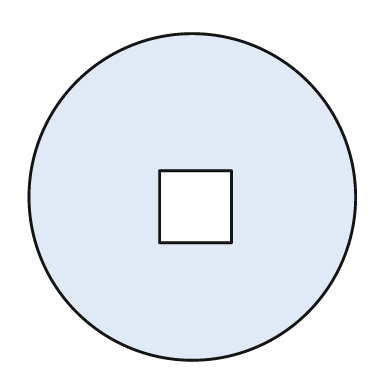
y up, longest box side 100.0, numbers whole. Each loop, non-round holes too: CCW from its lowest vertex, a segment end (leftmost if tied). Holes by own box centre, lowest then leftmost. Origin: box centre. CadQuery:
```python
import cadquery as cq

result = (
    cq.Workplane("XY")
    .moveTo(0.0, 0.0)
    .circle(50.0)
    .moveTo(-10.0, -14.0)
    .lineTo(12.0, -14.0)
    .lineTo(12.0, 8.0)
    .lineTo(-10.0, 8.0)
    .close()
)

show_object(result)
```